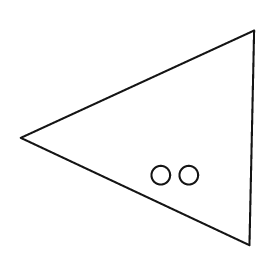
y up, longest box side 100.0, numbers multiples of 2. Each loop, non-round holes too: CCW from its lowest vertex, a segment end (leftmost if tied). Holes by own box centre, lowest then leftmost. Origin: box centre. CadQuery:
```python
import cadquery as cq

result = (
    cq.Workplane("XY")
    .moveTo(48.0, -46.0)
    .lineTo(50.0, 46.0)
    .lineTo(-50.0, 0.0)
    .close()
    .moveTo(10.0, -16.0)
    .circle(4.0)
    .moveTo(22.0, -16.0)
    .circle(4.0)
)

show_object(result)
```